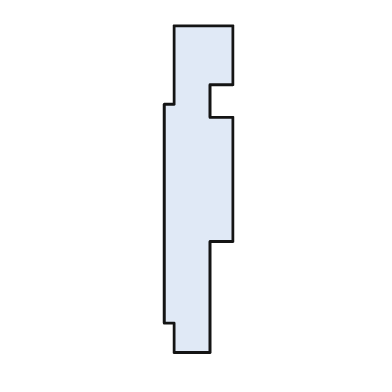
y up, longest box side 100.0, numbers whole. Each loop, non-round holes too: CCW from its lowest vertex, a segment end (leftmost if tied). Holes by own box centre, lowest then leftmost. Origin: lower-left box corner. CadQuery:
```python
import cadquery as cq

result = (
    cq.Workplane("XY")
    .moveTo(3.0, 0.0)
    .lineTo(14.0, 0.0)
    .lineTo(14.0, 34.0)
    .lineTo(21.0, 34.0)
    .lineTo(21.0, 72.0)
    .lineTo(14.0, 72.0)
    .lineTo(14.0, 82.0)
    .lineTo(21.0, 82.0)
    .lineTo(21.0, 100.0)
    .lineTo(3.0, 100.0)
    .lineTo(3.0, 76.0)
    .lineTo(0.0, 76.0)
    .lineTo(0.0, 9.0)
    .lineTo(3.0, 9.0)
    .close()
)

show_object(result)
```